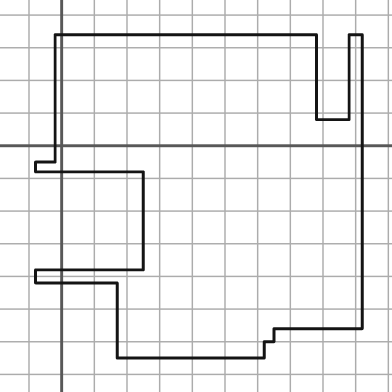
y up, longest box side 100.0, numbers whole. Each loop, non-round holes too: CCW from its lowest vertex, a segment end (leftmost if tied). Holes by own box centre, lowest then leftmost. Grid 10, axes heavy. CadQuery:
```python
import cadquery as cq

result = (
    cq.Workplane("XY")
    .moveTo(17.0, -65.0)
    .lineTo(62.0, -65.0)
    .lineTo(62.0, -60.0)
    .lineTo(65.0, -60.0)
    .lineTo(65.0, -56.0)
    .lineTo(92.0, -56.0)
    .lineTo(92.0, 34.0)
    .lineTo(88.0, 34.0)
    .lineTo(88.0, 8.0)
    .lineTo(78.0, 8.0)
    .lineTo(78.0, 34.0)
    .lineTo(-2.0, 34.0)
    .lineTo(-2.0, -5.0)
    .lineTo(-8.0, -5.0)
    .lineTo(-8.0, -8.0)
    .lineTo(25.0, -8.0)
    .lineTo(25.0, -38.0)
    .lineTo(-8.0, -38.0)
    .lineTo(-8.0, -42.0)
    .lineTo(17.0, -42.0)
    .close()
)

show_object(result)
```